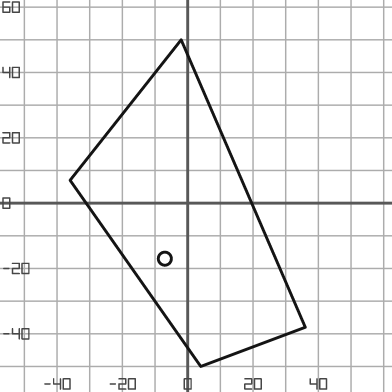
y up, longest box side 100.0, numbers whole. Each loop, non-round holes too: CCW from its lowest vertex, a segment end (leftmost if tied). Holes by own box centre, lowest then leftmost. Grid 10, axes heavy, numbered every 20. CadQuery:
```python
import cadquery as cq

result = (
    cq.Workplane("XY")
    .moveTo(4.0, -50.0)
    .lineTo(36.0, -38.0)
    .lineTo(-2.0, 50.0)
    .lineTo(-36.0, 7.0)
    .close()
    .moveTo(-7.0, -17.0)
    .circle(2.0)
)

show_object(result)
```